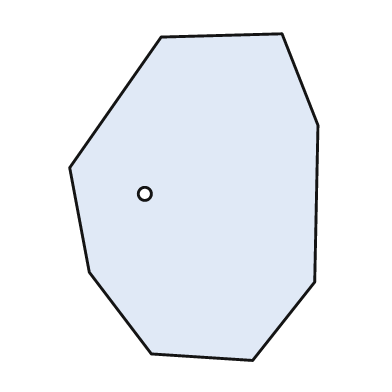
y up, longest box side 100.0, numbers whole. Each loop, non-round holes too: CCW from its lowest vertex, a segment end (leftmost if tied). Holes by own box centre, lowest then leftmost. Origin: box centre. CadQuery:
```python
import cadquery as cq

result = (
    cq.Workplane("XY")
    .moveTo(18.0, -50.0)
    .lineTo(37.0, -26.0)
    .lineTo(38.0, 22.0)
    .lineTo(27.0, 50.0)
    .lineTo(-10.0, 49.0)
    .lineTo(-38.0, 9.0)
    .lineTo(-32.0, -23.0)
    .lineTo(-13.0, -48.0)
    .close()
    .moveTo(-15.0, 1.0)
    .circle(2.0)
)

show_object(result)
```